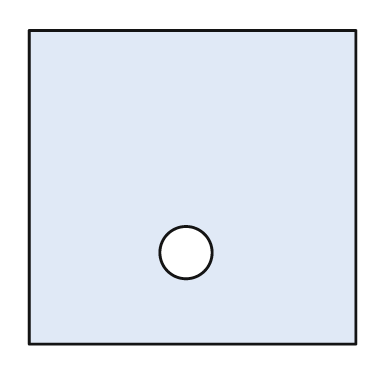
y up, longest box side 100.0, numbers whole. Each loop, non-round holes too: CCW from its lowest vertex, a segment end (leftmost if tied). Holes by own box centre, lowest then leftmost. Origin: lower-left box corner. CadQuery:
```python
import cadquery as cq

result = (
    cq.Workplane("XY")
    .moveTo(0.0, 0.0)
    .lineTo(100.0, 0.0)
    .lineTo(100.0, 96.0)
    .lineTo(0.0, 96.0)
    .close()
    .moveTo(48.0, 28.0)
    .circle(8.0)
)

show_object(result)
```